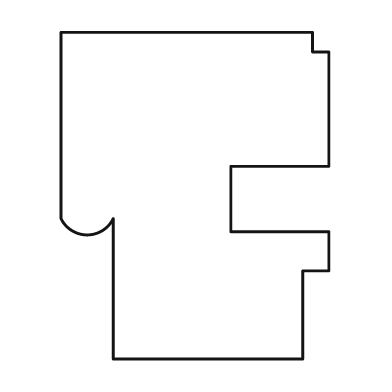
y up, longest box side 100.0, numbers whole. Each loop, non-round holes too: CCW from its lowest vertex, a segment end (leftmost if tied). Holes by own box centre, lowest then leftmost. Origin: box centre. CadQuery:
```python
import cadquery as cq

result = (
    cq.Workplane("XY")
    .moveTo(-25.0, -50.0)
    .lineTo(33.0, -50.0)
    .lineTo(33.0, -23.0)
    .lineTo(41.0, -23.0)
    .lineTo(41.0, -11.0)
    .lineTo(11.0, -11.0)
    .lineTo(11.0, 9.0)
    .lineTo(41.0, 9.0)
    .lineTo(41.0, 44.0)
    .lineTo(36.0, 44.0)
    .lineTo(36.0, 50.0)
    .lineTo(-41.0, 50.0)
    .lineTo(-41.0, -7.0)
    .threePointArc((-33.0, -12.0), (-25.0, -7.0))
    .close()
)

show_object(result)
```